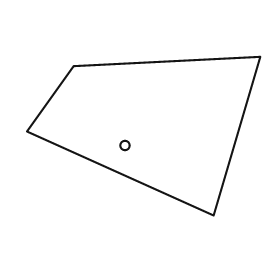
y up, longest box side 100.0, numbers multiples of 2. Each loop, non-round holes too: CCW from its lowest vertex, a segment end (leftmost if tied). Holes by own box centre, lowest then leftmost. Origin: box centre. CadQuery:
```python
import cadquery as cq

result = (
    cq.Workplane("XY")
    .moveTo(30.0, -34.0)
    .lineTo(50.0, 34.0)
    .lineTo(-30.0, 30.0)
    .lineTo(-50.0, 2.0)
    .close()
    .moveTo(-8.0, -4.0)
    .circle(2.0)
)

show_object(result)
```